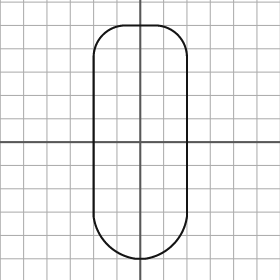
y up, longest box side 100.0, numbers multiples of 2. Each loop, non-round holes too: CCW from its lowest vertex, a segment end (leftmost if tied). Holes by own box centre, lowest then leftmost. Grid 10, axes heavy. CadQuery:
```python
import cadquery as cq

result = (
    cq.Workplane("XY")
    .moveTo(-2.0, -50.0)
    .lineTo(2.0, -50.0)
    .threePointArc((14.0, -44.0), (20.0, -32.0))
    .lineTo(20.0, 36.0)
    .threePointArc((16.0, 46.0), (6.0, 50.0))
    .lineTo(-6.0, 50.0)
    .threePointArc((-16.0, 46.0), (-20.0, 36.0))
    .lineTo(-20.0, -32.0)
    .threePointArc((-14.0, -44.0), (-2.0, -50.0))
    .close()
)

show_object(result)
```